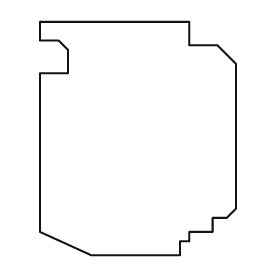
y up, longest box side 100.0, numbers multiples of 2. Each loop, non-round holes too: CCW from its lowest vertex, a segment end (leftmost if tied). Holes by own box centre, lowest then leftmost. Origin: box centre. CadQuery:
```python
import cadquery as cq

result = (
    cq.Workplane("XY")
    .moveTo(-20.0, -50.0)
    .lineTo(18.0, -50.0)
    .lineTo(18.0, -44.0)
    .lineTo(22.0, -44.0)
    .lineTo(22.0, -40.0)
    .lineTo(32.0, -40.0)
    .lineTo(32.0, -34.0)
    .lineTo(38.0, -34.0)
    .lineTo(42.0, -30.0)
    .lineTo(42.0, 32.0)
    .lineTo(34.0, 40.0)
    .lineTo(22.0, 40.0)
    .lineTo(22.0, 50.0)
    .lineTo(-42.0, 50.0)
    .lineTo(-42.0, 42.0)
    .lineTo(-34.0, 42.0)
    .lineTo(-30.0, 38.0)
    .lineTo(-30.0, 28.0)
    .lineTo(-42.0, 28.0)
    .lineTo(-42.0, -40.0)
    .close()
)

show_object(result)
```